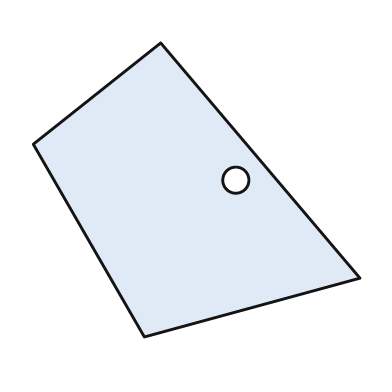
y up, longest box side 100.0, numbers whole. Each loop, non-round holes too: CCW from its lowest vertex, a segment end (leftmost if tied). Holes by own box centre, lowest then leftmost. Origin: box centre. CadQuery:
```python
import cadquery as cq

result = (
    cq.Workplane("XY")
    .moveTo(-16.0, -45.0)
    .lineTo(50.0, -27.0)
    .lineTo(-11.0, 45.0)
    .lineTo(-50.0, 14.0)
    .close()
    .moveTo(12.0, 3.0)
    .circle(4.0)
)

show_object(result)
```